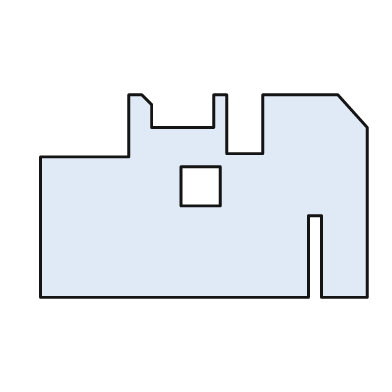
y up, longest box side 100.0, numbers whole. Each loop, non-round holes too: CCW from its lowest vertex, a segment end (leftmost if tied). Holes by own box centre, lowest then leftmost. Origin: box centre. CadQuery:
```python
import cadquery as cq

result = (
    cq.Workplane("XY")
    .moveTo(-50.0, -31.0)
    .lineTo(32.0, -31.0)
    .lineTo(32.0, -6.0)
    .lineTo(36.0, -6.0)
    .lineTo(36.0, -31.0)
    .lineTo(50.0, -31.0)
    .lineTo(50.0, 21.0)
    .lineTo(41.0, 31.0)
    .lineTo(18.0, 31.0)
    .lineTo(18.0, 13.0)
    .lineTo(7.0, 13.0)
    .lineTo(7.0, 31.0)
    .lineTo(3.0, 31.0)
    .lineTo(3.0, 21.0)
    .lineTo(-16.0, 21.0)
    .lineTo(-16.0, 28.0)
    .lineTo(-19.0, 31.0)
    .lineTo(-23.0, 31.0)
    .lineTo(-23.0, 12.0)
    .lineTo(-50.0, 12.0)
    .close()
    .moveTo(-7.0, -3.0)
    .lineTo(5.0, -3.0)
    .lineTo(5.0, 9.0)
    .lineTo(-7.0, 9.0)
    .close()
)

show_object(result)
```